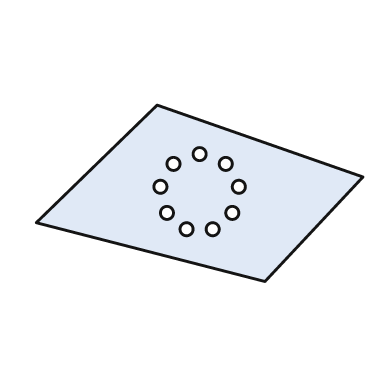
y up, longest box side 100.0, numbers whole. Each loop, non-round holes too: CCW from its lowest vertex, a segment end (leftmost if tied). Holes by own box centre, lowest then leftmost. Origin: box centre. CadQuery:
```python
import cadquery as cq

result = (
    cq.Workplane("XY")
    .moveTo(20.0, -27.0)
    .lineTo(50.0, 5.0)
    .lineTo(-13.0, 27.0)
    .lineTo(-50.0, -9.0)
    .close()
    .moveTo(-4.0, -11.0)
    .circle(2.0)
    .moveTo(4.0, -11.0)
    .circle(2.0)
    .moveTo(-10.0, -6.0)
    .circle(2.0)
    .moveTo(10.0, -6.0)
    .circle(2.0)
    .moveTo(-12.0, 2.0)
    .circle(2.0)
    .moveTo(12.0, 2.0)
    .circle(2.0)
    .moveTo(-8.0, 9.0)
    .circle(2.0)
    .moveTo(8.0, 9.0)
    .circle(2.0)
    .moveTo(0.0, 12.0)
    .circle(2.0)
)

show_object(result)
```